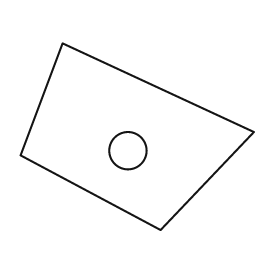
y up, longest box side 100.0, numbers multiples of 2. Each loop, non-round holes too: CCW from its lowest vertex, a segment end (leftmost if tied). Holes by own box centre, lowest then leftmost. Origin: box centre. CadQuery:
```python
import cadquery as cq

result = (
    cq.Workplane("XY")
    .moveTo(10.0, -40.0)
    .lineTo(50.0, 2.0)
    .lineTo(-32.0, 40.0)
    .lineTo(-50.0, -8.0)
    .close()
    .moveTo(-4.0, -6.0)
    .circle(8.0)
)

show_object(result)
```